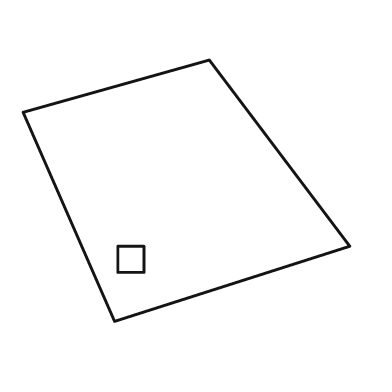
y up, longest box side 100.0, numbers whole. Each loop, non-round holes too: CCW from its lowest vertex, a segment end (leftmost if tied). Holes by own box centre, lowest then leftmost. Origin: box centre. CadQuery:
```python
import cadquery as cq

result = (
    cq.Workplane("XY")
    .moveTo(-22.0, -40.0)
    .lineTo(50.0, -17.0)
    .lineTo(7.0, 40.0)
    .lineTo(-50.0, 24.0)
    .close()
    .moveTo(-21.0, -25.0)
    .lineTo(-13.0, -25.0)
    .lineTo(-13.0, -17.0)
    .lineTo(-21.0, -17.0)
    .close()
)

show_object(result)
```